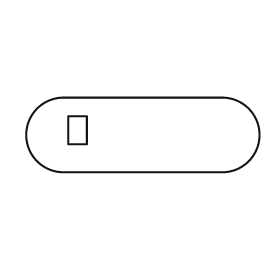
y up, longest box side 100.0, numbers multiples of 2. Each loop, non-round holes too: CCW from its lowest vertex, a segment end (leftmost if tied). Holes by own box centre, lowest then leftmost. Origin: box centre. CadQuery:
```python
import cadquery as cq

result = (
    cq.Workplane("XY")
    .moveTo(-34.0, -16.0)
    .lineTo(34.0, -16.0)
    .threePointArc((50.0, 0.0), (34.0, 16.0))
    .lineTo(-34.0, 16.0)
    .threePointArc((-50.0, 0.0), (-34.0, -16.0))
    .close()
    .moveTo(-32.0, -4.0)
    .lineTo(-24.0, -4.0)
    .lineTo(-24.0, 8.0)
    .lineTo(-32.0, 8.0)
    .close()
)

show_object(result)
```